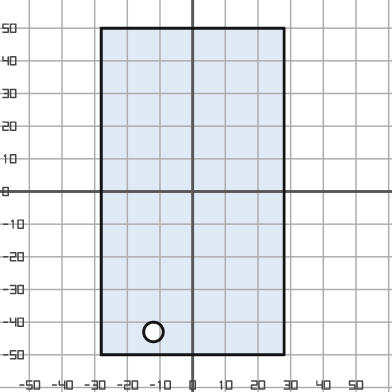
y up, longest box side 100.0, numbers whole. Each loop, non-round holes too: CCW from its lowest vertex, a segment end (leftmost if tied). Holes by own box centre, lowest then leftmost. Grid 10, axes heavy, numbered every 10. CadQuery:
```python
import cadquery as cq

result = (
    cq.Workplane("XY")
    .moveTo(-28.0, -50.0)
    .lineTo(28.0, -50.0)
    .lineTo(28.0, 50.0)
    .lineTo(-28.0, 50.0)
    .close()
    .moveTo(-12.0, -43.0)
    .circle(3.0)
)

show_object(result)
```